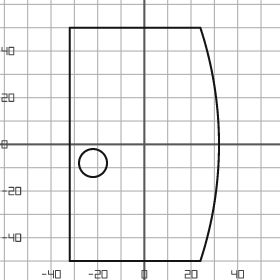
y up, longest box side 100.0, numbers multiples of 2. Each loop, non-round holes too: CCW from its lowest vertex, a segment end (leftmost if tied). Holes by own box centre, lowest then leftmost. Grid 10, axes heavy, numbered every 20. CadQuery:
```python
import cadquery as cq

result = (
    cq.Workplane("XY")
    .moveTo(-32.0, -50.0)
    .lineTo(24.0, -50.0)
    .threePointArc((32.0, 0.0), (24.0, 50.0))
    .lineTo(-32.0, 50.0)
    .close()
    .moveTo(-22.0, -8.0)
    .circle(6.0)
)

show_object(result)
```